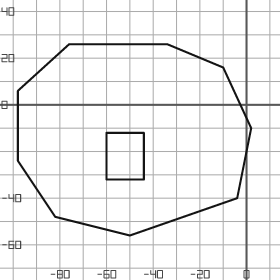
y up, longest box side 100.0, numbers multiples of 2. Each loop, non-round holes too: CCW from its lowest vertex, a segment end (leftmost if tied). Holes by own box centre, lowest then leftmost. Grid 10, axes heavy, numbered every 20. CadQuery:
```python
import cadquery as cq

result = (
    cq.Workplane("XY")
    .moveTo(-50.0, -56.0)
    .lineTo(-4.0, -40.0)
    .lineTo(2.0, -10.0)
    .lineTo(-10.0, 16.0)
    .lineTo(-34.0, 26.0)
    .lineTo(-76.0, 26.0)
    .lineTo(-98.0, 6.0)
    .lineTo(-98.0, -24.0)
    .lineTo(-82.0, -48.0)
    .close()
    .moveTo(-60.0, -32.0)
    .lineTo(-44.0, -32.0)
    .lineTo(-44.0, -12.0)
    .lineTo(-60.0, -12.0)
    .close()
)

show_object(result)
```